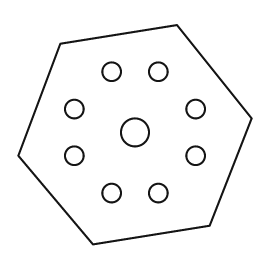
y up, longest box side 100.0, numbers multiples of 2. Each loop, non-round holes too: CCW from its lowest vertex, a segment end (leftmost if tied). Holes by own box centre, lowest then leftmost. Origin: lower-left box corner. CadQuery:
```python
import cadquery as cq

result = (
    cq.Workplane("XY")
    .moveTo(32.0, 0.0)
    .lineTo(82.0, 8.0)
    .lineTo(100.0, 54.0)
    .lineTo(68.0, 94.0)
    .lineTo(18.0, 86.0)
    .lineTo(0.0, 38.0)
    .close()
    .moveTo(40.0, 22.0)
    .circle(4.0)
    .moveTo(60.0, 22.0)
    .circle(4.0)
    .moveTo(24.0, 38.0)
    .circle(4.0)
    .moveTo(76.0, 38.0)
    .circle(4.0)
    .moveTo(50.0, 48.0)
    .circle(6.0)
    .moveTo(24.0, 58.0)
    .circle(4.0)
    .moveTo(76.0, 58.0)
    .circle(4.0)
    .moveTo(40.0, 74.0)
    .circle(4.0)
    .moveTo(60.0, 74.0)
    .circle(4.0)
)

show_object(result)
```